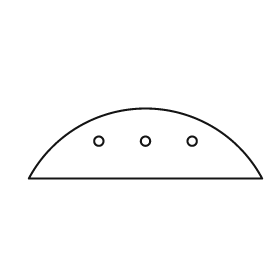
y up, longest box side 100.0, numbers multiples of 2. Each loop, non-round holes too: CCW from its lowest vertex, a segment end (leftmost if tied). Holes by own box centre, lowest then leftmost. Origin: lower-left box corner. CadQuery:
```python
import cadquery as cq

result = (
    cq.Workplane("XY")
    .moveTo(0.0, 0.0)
    .lineTo(100.0, 0.0)
    .threePointArc((50.0, 30.0), (0.0, 0.0))
    .close()
    .moveTo(30.0, 16.0)
    .circle(2.0)
    .moveTo(50.0, 16.0)
    .circle(2.0)
    .moveTo(70.0, 16.0)
    .circle(2.0)
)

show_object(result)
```